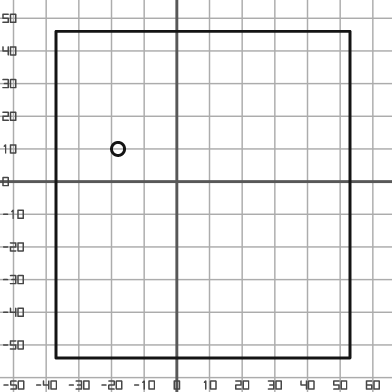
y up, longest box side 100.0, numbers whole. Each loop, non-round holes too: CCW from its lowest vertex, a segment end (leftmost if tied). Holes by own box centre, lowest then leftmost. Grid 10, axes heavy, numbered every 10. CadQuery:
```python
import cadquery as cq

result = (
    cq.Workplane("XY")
    .moveTo(-37.0, -54.0)
    .lineTo(53.0, -54.0)
    .lineTo(53.0, 46.0)
    .lineTo(-37.0, 46.0)
    .close()
    .moveTo(-18.0, 10.0)
    .circle(2.0)
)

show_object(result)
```